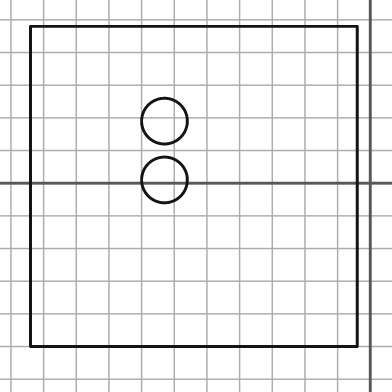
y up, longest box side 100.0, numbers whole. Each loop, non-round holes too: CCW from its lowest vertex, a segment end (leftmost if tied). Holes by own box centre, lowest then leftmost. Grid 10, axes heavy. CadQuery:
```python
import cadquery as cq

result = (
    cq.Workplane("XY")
    .moveTo(-104.0, -50.0)
    .lineTo(-4.0, -50.0)
    .lineTo(-4.0, 48.0)
    .lineTo(-104.0, 48.0)
    .close()
    .moveTo(-63.0, 1.0)
    .circle(7.0)
    .moveTo(-63.0, 19.0)
    .circle(7.0)
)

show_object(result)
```